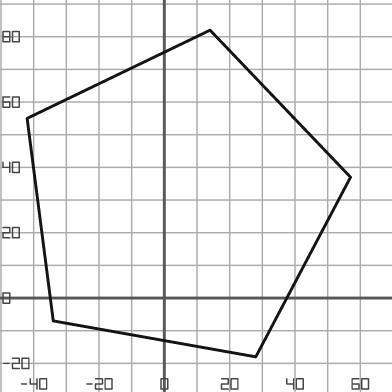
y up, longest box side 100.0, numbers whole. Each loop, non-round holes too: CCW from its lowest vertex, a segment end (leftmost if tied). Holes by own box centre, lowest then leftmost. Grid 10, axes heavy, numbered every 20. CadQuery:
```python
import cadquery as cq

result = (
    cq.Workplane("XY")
    .moveTo(28.0, -18.0)
    .lineTo(57.0, 37.0)
    .lineTo(14.0, 82.0)
    .lineTo(-42.0, 55.0)
    .lineTo(-34.0, -7.0)
    .close()
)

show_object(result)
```